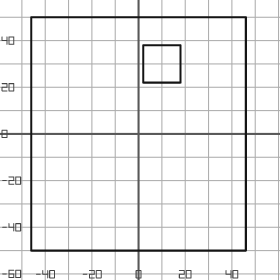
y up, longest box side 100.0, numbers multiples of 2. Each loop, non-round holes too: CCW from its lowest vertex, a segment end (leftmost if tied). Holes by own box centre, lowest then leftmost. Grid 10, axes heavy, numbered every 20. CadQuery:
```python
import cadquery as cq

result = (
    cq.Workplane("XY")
    .moveTo(-46.0, -50.0)
    .lineTo(46.0, -50.0)
    .lineTo(46.0, 50.0)
    .lineTo(-46.0, 50.0)
    .close()
    .moveTo(2.0, 22.0)
    .lineTo(18.0, 22.0)
    .lineTo(18.0, 38.0)
    .lineTo(2.0, 38.0)
    .close()
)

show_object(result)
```